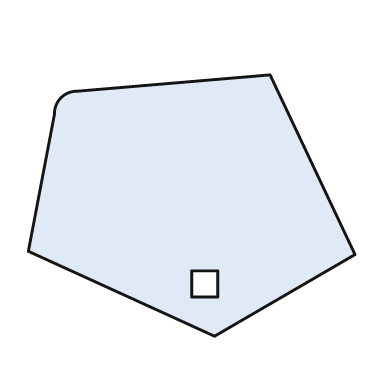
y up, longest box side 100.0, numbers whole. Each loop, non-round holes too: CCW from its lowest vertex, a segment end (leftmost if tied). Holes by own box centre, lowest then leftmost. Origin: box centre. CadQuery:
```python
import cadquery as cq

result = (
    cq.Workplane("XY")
    .moveTo(7.0, -40.0)
    .lineTo(50.0, -15.0)
    .lineTo(24.0, 40.0)
    .lineTo(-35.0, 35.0)
    .threePointArc((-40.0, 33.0), (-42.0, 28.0))
    .lineTo(-50.0, -14.0)
    .close()
    .moveTo(0.0, -28.0)
    .lineTo(8.0, -28.0)
    .lineTo(8.0, -20.0)
    .lineTo(0.0, -20.0)
    .close()
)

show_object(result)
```